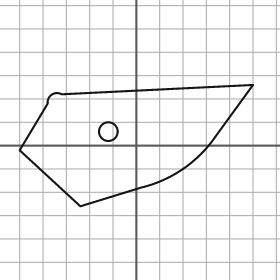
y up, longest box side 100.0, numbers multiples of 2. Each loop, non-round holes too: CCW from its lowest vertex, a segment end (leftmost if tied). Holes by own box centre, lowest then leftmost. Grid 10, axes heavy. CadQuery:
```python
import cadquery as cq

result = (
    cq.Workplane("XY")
    .moveTo(-24.0, -26.0)
    .lineTo(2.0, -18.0)
    .threePointArc((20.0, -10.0), (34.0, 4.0))
    .lineTo(50.0, 26.0)
    .lineTo(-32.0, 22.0)
    .threePointArc((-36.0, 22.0), (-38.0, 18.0))
    .lineTo(-50.0, -2.0)
    .close()
    .moveTo(-12.0, 6.0)
    .circle(4.0)
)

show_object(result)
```